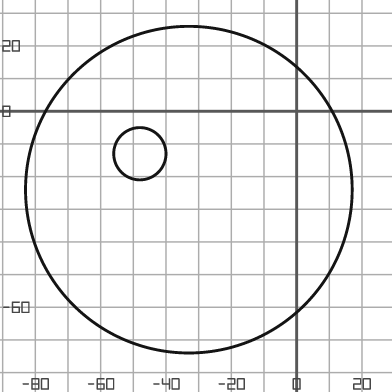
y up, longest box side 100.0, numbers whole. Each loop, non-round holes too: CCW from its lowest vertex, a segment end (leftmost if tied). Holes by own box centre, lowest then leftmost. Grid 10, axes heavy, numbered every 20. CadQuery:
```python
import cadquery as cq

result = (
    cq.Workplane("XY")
    .moveTo(-33.0, -24.0)
    .circle(50.0)
    .moveTo(-48.0, -13.0)
    .circle(8.0)
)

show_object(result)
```